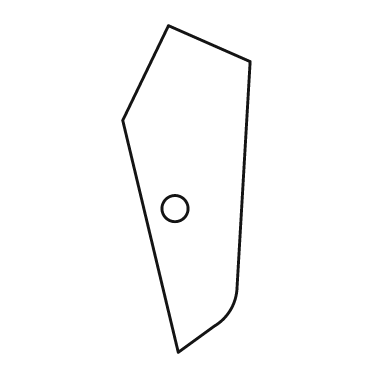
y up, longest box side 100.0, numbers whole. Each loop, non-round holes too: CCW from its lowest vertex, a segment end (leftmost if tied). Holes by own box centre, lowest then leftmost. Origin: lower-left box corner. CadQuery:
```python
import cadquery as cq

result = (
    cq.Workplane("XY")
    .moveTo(17.0, 0.0)
    .lineTo(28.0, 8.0)
    .threePointArc((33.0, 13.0), (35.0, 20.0))
    .lineTo(39.0, 89.0)
    .lineTo(14.0, 100.0)
    .lineTo(0.0, 71.0)
    .close()
    .moveTo(16.0, 44.0)
    .circle(4.0)
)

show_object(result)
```